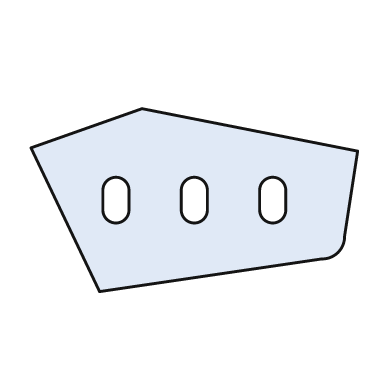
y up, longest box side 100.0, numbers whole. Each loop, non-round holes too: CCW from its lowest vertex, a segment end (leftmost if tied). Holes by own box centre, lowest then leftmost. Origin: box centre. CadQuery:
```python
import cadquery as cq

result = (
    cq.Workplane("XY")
    .moveTo(-29.0, -28.0)
    .lineTo(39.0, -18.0)
    .threePointArc((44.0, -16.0), (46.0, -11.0))
    .lineTo(50.0, 15.0)
    .lineTo(-16.0, 28.0)
    .lineTo(-50.0, 16.0)
    .close()
    .moveTo(-28.0, -3.0)
    .threePointArc((-24.0, -7.0), (-20.0, -3.0))
    .lineTo(-20.0, 3.0)
    .threePointArc((-24.0, 7.0), (-28.0, 3.0))
    .close()
    .moveTo(-4.0, -3.0)
    .threePointArc((0.0, -7.0), (4.0, -3.0))
    .lineTo(4.0, 3.0)
    .threePointArc((0.0, 7.0), (-4.0, 3.0))
    .close()
    .moveTo(20.0, -3.0)
    .threePointArc((24.0, -7.0), (28.0, -3.0))
    .lineTo(28.0, 3.0)
    .threePointArc((24.0, 7.0), (20.0, 3.0))
    .close()
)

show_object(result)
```